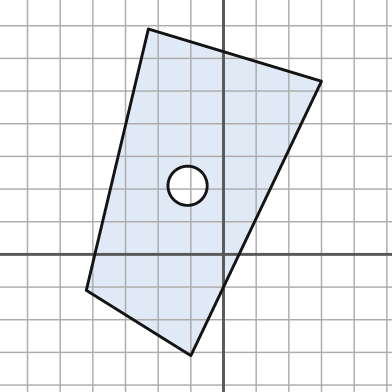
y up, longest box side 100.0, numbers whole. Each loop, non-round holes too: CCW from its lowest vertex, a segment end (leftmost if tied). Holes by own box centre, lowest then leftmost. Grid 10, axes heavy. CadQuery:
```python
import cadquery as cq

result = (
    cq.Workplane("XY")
    .moveTo(-10.0, -31.0)
    .lineTo(30.0, 53.0)
    .lineTo(-23.0, 69.0)
    .lineTo(-42.0, -11.0)
    .close()
    .moveTo(-11.0, 21.0)
    .circle(6.0)
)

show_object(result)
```